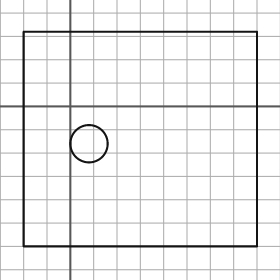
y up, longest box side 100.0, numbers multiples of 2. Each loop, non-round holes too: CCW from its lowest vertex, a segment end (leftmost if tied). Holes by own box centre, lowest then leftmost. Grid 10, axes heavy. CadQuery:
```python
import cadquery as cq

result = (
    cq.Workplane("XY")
    .moveTo(-20.0, -60.0)
    .lineTo(80.0, -60.0)
    .lineTo(80.0, 32.0)
    .lineTo(-20.0, 32.0)
    .close()
    .moveTo(8.0, -16.0)
    .circle(8.0)
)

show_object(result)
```